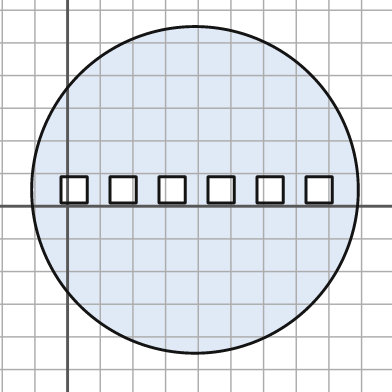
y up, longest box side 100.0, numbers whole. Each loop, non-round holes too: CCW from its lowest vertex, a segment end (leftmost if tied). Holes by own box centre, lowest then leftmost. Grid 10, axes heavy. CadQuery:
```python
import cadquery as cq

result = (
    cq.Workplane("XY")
    .moveTo(39.0, 5.0)
    .circle(50.0)
    .moveTo(-2.0, 1.0)
    .lineTo(6.0, 1.0)
    .lineTo(6.0, 9.0)
    .lineTo(-2.0, 9.0)
    .close()
    .moveTo(13.0, 1.0)
    .lineTo(21.0, 1.0)
    .lineTo(21.0, 9.0)
    .lineTo(13.0, 9.0)
    .close()
    .moveTo(28.0, 1.0)
    .lineTo(36.0, 1.0)
    .lineTo(36.0, 9.0)
    .lineTo(28.0, 9.0)
    .close()
    .moveTo(43.0, 1.0)
    .lineTo(51.0, 1.0)
    .lineTo(51.0, 9.0)
    .lineTo(43.0, 9.0)
    .close()
    .moveTo(58.0, 1.0)
    .lineTo(66.0, 1.0)
    .lineTo(66.0, 9.0)
    .lineTo(58.0, 9.0)
    .close()
    .moveTo(73.0, 1.0)
    .lineTo(81.0, 1.0)
    .lineTo(81.0, 9.0)
    .lineTo(73.0, 9.0)
    .close()
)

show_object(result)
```